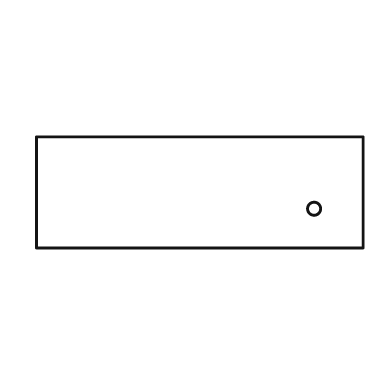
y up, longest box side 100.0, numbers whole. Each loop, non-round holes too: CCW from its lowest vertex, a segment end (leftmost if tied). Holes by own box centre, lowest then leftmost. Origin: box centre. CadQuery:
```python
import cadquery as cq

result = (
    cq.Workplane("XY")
    .moveTo(-50.0, -17.0)
    .lineTo(50.0, -17.0)
    .lineTo(50.0, 17.0)
    .lineTo(-50.0, 17.0)
    .close()
    .moveTo(35.0, -5.0)
    .circle(2.0)
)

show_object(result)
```